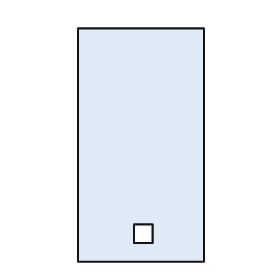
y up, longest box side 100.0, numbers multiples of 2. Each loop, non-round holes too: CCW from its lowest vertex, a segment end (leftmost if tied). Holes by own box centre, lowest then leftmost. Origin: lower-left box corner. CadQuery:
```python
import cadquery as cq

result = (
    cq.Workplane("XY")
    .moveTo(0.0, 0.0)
    .lineTo(54.0, 0.0)
    .lineTo(54.0, 100.0)
    .lineTo(0.0, 100.0)
    .close()
    .moveTo(24.0, 8.0)
    .lineTo(32.0, 8.0)
    .lineTo(32.0, 16.0)
    .lineTo(24.0, 16.0)
    .close()
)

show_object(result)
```